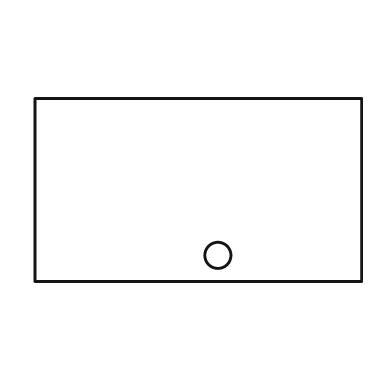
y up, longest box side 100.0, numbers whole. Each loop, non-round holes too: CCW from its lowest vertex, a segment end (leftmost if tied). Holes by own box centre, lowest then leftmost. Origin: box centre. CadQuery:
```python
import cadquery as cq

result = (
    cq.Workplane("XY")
    .moveTo(-50.0, -28.0)
    .lineTo(50.0, -28.0)
    .lineTo(50.0, 28.0)
    .lineTo(-50.0, 28.0)
    .close()
    .moveTo(6.0, -20.0)
    .circle(4.0)
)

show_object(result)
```